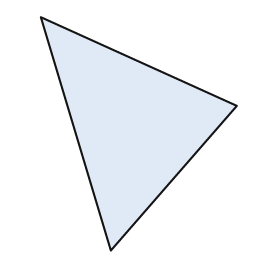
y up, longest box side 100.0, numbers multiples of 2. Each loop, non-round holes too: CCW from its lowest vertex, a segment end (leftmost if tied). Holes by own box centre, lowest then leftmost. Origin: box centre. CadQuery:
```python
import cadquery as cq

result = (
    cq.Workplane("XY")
    .moveTo(-12.0, -50.0)
    .lineTo(42.0, 12.0)
    .lineTo(-42.0, 50.0)
    .close()
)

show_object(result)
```